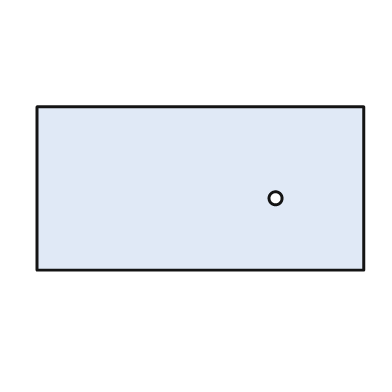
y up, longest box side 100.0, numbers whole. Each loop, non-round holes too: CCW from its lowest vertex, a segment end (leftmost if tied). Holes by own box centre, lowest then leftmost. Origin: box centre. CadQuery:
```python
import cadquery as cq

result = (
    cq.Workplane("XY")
    .moveTo(-50.0, -25.0)
    .lineTo(50.0, -25.0)
    .lineTo(50.0, 25.0)
    .lineTo(-50.0, 25.0)
    .close()
    .moveTo(23.0, -3.0)
    .circle(2.0)
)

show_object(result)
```